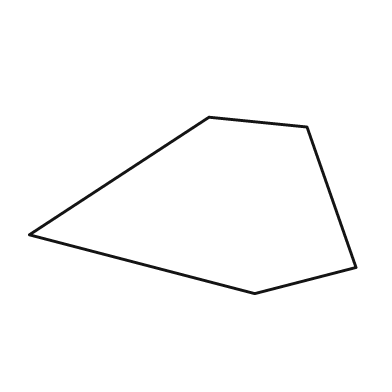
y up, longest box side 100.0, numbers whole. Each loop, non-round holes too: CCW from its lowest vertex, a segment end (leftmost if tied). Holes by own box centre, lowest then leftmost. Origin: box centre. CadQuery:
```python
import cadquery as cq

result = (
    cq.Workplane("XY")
    .moveTo(19.0, -27.0)
    .lineTo(50.0, -19.0)
    .lineTo(35.0, 24.0)
    .lineTo(5.0, 27.0)
    .lineTo(-50.0, -9.0)
    .close()
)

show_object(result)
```